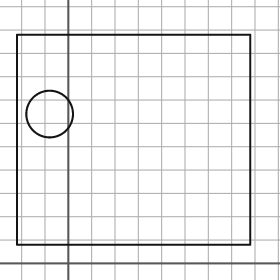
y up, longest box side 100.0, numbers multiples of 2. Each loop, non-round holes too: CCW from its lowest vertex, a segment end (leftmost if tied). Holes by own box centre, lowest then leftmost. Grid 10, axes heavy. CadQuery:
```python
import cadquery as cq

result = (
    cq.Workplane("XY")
    .moveTo(-22.0, 8.0)
    .lineTo(78.0, 8.0)
    .lineTo(78.0, 98.0)
    .lineTo(-22.0, 98.0)
    .close()
    .moveTo(-8.0, 64.0)
    .circle(10.0)
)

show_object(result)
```